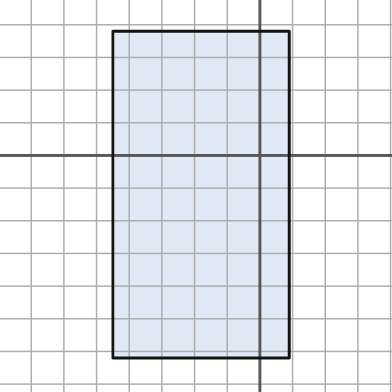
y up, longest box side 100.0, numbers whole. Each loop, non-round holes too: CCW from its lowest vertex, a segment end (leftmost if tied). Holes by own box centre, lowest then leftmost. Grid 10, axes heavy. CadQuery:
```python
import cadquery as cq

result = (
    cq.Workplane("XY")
    .moveTo(-45.0, -62.0)
    .lineTo(9.0, -62.0)
    .lineTo(9.0, 38.0)
    .lineTo(-45.0, 38.0)
    .close()
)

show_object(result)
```